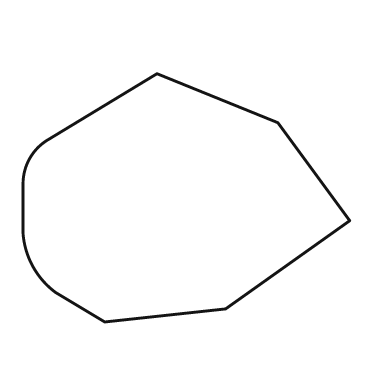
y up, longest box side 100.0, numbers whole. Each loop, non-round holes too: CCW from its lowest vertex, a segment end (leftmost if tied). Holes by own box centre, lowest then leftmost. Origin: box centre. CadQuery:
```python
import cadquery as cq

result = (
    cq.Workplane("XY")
    .moveTo(-25.0, -38.0)
    .lineTo(12.0, -34.0)
    .lineTo(50.0, -7.0)
    .lineTo(28.0, 23.0)
    .lineTo(-9.0, 38.0)
    .lineTo(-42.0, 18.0)
    .threePointArc((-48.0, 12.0), (-50.0, 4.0))
    .lineTo(-50.0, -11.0)
    .threePointArc((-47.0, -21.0), (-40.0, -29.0))
    .close()
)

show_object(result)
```